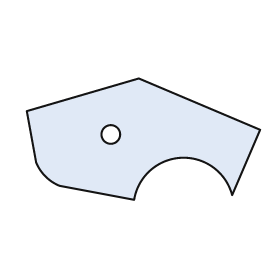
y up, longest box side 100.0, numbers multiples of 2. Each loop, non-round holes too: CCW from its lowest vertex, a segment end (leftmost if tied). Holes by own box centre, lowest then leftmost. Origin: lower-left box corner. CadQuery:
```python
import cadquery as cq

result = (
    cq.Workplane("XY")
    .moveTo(46.0, 0.0)
    .threePointArc((66.0, 18.0), (88.0, 2.0))
    .lineTo(100.0, 30.0)
    .lineTo(48.0, 52.0)
    .lineTo(0.0, 38.0)
    .lineTo(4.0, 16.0)
    .threePointArc((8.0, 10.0), (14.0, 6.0))
    .close()
    .moveTo(36.0, 28.0)
    .circle(4.0)
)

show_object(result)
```